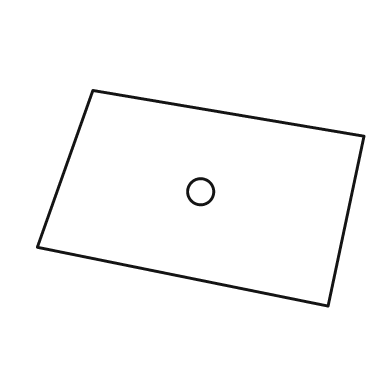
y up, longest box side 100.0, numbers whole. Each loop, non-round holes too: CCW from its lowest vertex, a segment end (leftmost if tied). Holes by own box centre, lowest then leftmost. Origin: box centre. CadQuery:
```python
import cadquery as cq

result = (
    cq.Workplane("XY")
    .moveTo(39.0, -33.0)
    .lineTo(50.0, 19.0)
    .lineTo(-33.0, 33.0)
    .lineTo(-50.0, -15.0)
    .close()
    .moveTo(0.0, 2.0)
    .circle(4.0)
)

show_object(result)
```